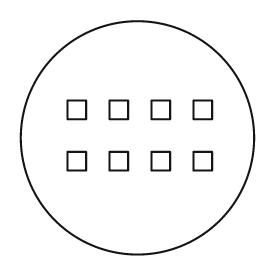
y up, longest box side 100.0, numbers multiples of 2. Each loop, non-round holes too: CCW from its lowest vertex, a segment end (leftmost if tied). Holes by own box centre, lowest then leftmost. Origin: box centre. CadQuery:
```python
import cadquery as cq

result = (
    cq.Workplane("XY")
    .moveTo(0.0, 0.0)
    .circle(50.0)
    .moveTo(-30.0, -14.0)
    .lineTo(-22.0, -14.0)
    .lineTo(-22.0, -6.0)
    .lineTo(-30.0, -6.0)
    .close()
    .moveTo(-12.0, -14.0)
    .lineTo(-4.0, -14.0)
    .lineTo(-4.0, -6.0)
    .lineTo(-12.0, -6.0)
    .close()
    .moveTo(6.0, -14.0)
    .lineTo(14.0, -14.0)
    .lineTo(14.0, -6.0)
    .lineTo(6.0, -6.0)
    .close()
    .moveTo(24.0, -14.0)
    .lineTo(32.0, -14.0)
    .lineTo(32.0, -6.0)
    .lineTo(24.0, -6.0)
    .close()
    .moveTo(-30.0, 8.0)
    .lineTo(-22.0, 8.0)
    .lineTo(-22.0, 16.0)
    .lineTo(-30.0, 16.0)
    .close()
    .moveTo(-12.0, 8.0)
    .lineTo(-4.0, 8.0)
    .lineTo(-4.0, 16.0)
    .lineTo(-12.0, 16.0)
    .close()
    .moveTo(6.0, 8.0)
    .lineTo(14.0, 8.0)
    .lineTo(14.0, 16.0)
    .lineTo(6.0, 16.0)
    .close()
    .moveTo(24.0, 8.0)
    .lineTo(32.0, 8.0)
    .lineTo(32.0, 16.0)
    .lineTo(24.0, 16.0)
    .close()
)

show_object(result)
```